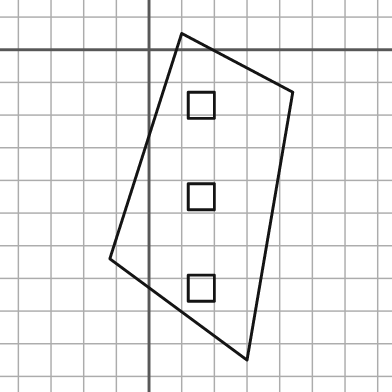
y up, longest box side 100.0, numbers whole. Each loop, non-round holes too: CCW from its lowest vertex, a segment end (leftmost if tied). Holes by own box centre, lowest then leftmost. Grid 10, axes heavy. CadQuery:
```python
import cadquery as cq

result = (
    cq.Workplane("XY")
    .moveTo(30.0, -95.0)
    .lineTo(44.0, -13.0)
    .lineTo(10.0, 5.0)
    .lineTo(-12.0, -64.0)
    .close()
    .moveTo(12.0, -77.0)
    .lineTo(20.0, -77.0)
    .lineTo(20.0, -69.0)
    .lineTo(12.0, -69.0)
    .close()
    .moveTo(12.0, -49.0)
    .lineTo(20.0, -49.0)
    .lineTo(20.0, -41.0)
    .lineTo(12.0, -41.0)
    .close()
    .moveTo(12.0, -21.0)
    .lineTo(20.0, -21.0)
    .lineTo(20.0, -13.0)
    .lineTo(12.0, -13.0)
    .close()
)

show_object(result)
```